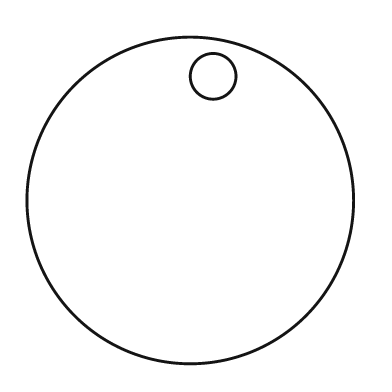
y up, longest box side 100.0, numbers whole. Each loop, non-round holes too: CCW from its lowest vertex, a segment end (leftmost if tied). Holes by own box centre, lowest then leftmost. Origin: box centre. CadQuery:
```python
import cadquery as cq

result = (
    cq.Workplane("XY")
    .moveTo(0.0, 0.0)
    .circle(50.0)
    .moveTo(7.0, 38.0)
    .circle(7.0)
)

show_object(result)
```